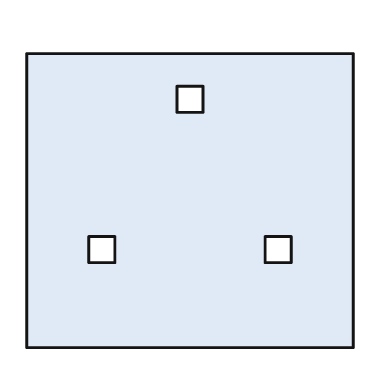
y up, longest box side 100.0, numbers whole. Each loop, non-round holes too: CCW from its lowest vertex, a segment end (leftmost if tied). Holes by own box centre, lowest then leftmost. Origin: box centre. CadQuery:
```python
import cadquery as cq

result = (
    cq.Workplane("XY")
    .moveTo(-50.0, -45.0)
    .lineTo(50.0, -45.0)
    .lineTo(50.0, 45.0)
    .lineTo(-50.0, 45.0)
    .close()
    .moveTo(-31.0, -19.0)
    .lineTo(-23.0, -19.0)
    .lineTo(-23.0, -11.0)
    .lineTo(-31.0, -11.0)
    .close()
    .moveTo(23.0, -19.0)
    .lineTo(31.0, -19.0)
    .lineTo(31.0, -11.0)
    .lineTo(23.0, -11.0)
    .close()
    .moveTo(-4.0, 27.0)
    .lineTo(4.0, 27.0)
    .lineTo(4.0, 35.0)
    .lineTo(-4.0, 35.0)
    .close()
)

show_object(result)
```